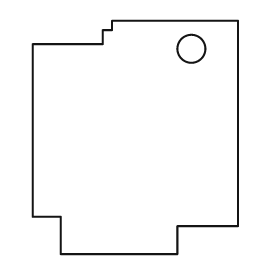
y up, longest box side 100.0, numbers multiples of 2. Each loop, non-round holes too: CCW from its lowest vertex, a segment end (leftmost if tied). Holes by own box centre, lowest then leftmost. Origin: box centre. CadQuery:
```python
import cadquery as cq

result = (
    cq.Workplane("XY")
    .moveTo(-32.0, -50.0)
    .lineTo(18.0, -50.0)
    .lineTo(18.0, -38.0)
    .lineTo(44.0, -38.0)
    .lineTo(44.0, 50.0)
    .lineTo(-10.0, 50.0)
    .lineTo(-10.0, 46.0)
    .lineTo(-14.0, 46.0)
    .lineTo(-14.0, 40.0)
    .lineTo(-44.0, 40.0)
    .lineTo(-44.0, -34.0)
    .lineTo(-32.0, -34.0)
    .close()
    .moveTo(24.0, 38.0)
    .circle(6.0)
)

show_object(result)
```